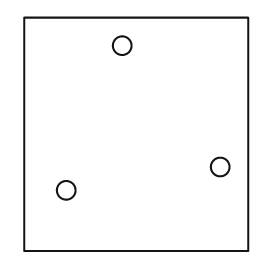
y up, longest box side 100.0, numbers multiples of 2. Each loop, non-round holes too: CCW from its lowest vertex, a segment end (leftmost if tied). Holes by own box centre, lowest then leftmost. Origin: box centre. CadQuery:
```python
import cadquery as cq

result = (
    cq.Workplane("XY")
    .moveTo(-48.0, -50.0)
    .lineTo(48.0, -50.0)
    .lineTo(48.0, 50.0)
    .lineTo(-48.0, 50.0)
    .close()
    .moveTo(-30.0, -24.0)
    .circle(4.0)
    .moveTo(36.0, -14.0)
    .circle(4.0)
    .moveTo(-6.0, 38.0)
    .circle(4.0)
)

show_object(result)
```